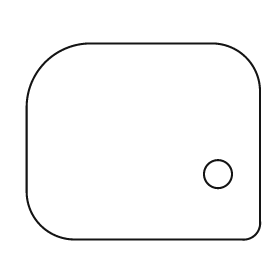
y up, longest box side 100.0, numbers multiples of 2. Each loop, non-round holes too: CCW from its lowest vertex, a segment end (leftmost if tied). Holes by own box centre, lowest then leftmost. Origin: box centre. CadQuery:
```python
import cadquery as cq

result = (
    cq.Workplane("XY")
    .moveTo(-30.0, -42.0)
    .lineTo(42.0, -42.0)
    .threePointArc((48.0, -40.0), (50.0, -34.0))
    .lineTo(50.0, 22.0)
    .threePointArc((44.0, 36.0), (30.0, 42.0))
    .lineTo(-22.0, 42.0)
    .threePointArc((-42.0, 34.0), (-50.0, 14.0))
    .lineTo(-50.0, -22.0)
    .threePointArc((-44.0, -36.0), (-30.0, -42.0))
    .close()
    .moveTo(32.0, -14.0)
    .circle(6.0)
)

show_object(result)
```